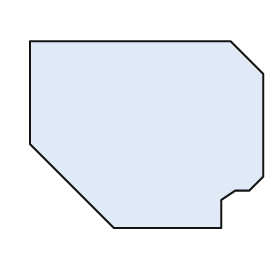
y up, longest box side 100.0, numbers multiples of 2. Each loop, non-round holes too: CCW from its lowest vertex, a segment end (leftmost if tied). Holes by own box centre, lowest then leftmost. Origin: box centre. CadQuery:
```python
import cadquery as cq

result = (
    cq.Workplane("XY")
    .moveTo(-14.0, -40.0)
    .lineTo(32.0, -40.0)
    .lineTo(32.0, -28.0)
    .lineTo(38.0, -24.0)
    .lineTo(44.0, -24.0)
    .lineTo(50.0, -18.0)
    .lineTo(50.0, 26.0)
    .lineTo(36.0, 40.0)
    .lineTo(-50.0, 40.0)
    .lineTo(-50.0, -4.0)
    .close()
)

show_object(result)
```